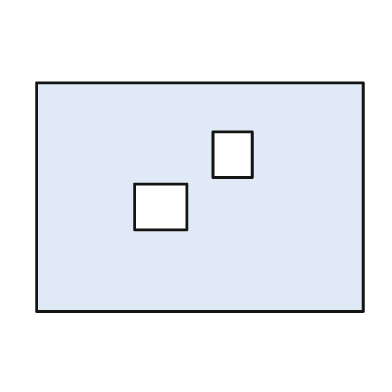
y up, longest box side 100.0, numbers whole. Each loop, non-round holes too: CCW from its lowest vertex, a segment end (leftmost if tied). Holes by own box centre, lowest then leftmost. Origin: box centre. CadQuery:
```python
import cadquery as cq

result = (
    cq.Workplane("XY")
    .moveTo(-50.0, -35.0)
    .lineTo(50.0, -35.0)
    .lineTo(50.0, 35.0)
    .lineTo(-50.0, 35.0)
    .close()
    .moveTo(-20.0, -10.0)
    .lineTo(-4.0, -10.0)
    .lineTo(-4.0, 4.0)
    .lineTo(-20.0, 4.0)
    .close()
    .moveTo(4.0, 6.0)
    .lineTo(16.0, 6.0)
    .lineTo(16.0, 20.0)
    .lineTo(4.0, 20.0)
    .close()
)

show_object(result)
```